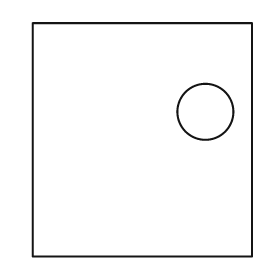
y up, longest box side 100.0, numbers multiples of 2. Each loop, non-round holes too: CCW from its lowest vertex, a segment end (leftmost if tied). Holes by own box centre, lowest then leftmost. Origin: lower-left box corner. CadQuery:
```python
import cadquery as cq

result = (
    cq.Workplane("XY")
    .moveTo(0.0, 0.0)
    .lineTo(94.0, 0.0)
    .lineTo(94.0, 100.0)
    .lineTo(0.0, 100.0)
    .close()
    .moveTo(74.0, 62.0)
    .circle(12.0)
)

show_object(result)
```